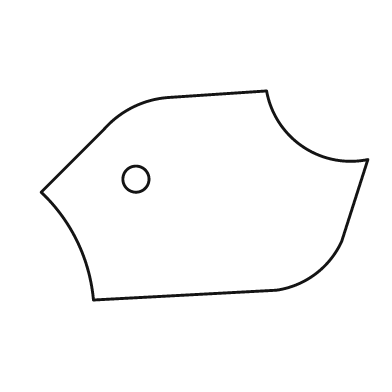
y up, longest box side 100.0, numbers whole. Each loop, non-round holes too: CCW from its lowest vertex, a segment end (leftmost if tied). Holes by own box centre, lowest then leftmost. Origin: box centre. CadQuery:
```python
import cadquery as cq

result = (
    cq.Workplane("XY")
    .moveTo(-34.0, -32.0)
    .lineTo(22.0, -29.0)
    .threePointArc((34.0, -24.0), (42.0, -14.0))
    .lineTo(50.0, 11.0)
    .threePointArc((30.0, 15.0), (19.0, 32.0))
    .lineTo(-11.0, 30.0)
    .threePointArc((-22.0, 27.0), (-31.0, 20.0))
    .lineTo(-50.0, 1.0)
    .threePointArc((-39.0, -14.0), (-34.0, -32.0))
    .close()
    .moveTo(-21.0, 5.0)
    .circle(4.0)
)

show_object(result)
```